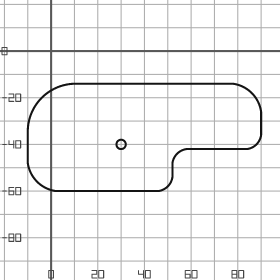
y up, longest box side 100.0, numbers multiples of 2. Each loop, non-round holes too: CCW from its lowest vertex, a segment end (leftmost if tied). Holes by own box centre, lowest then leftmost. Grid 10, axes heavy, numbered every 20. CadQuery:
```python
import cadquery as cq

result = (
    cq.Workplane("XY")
    .moveTo(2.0, -60.0)
    .lineTo(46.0, -60.0)
    .threePointArc((50.0, -58.0), (52.0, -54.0))
    .lineTo(52.0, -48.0)
    .threePointArc((54.0, -44.0), (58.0, -42.0))
    .lineTo(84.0, -42.0)
    .threePointArc((88.0, -40.0), (90.0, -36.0))
    .lineTo(90.0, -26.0)
    .threePointArc((86.0, -18.0), (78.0, -14.0))
    .lineTo(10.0, -14.0)
    .threePointArc((-4.0, -20.0), (-10.0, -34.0))
    .lineTo(-10.0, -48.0)
    .threePointArc((-6.0, -56.0), (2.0, -60.0))
    .close()
    .moveTo(30.0, -40.0)
    .circle(2.0)
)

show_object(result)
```